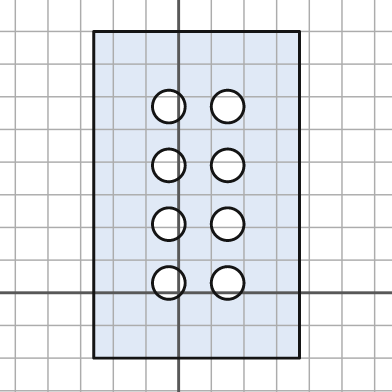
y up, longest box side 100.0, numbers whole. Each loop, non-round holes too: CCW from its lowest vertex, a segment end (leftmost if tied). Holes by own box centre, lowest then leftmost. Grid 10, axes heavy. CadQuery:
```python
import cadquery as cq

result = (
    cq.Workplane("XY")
    .moveTo(-26.0, -20.0)
    .lineTo(37.0, -20.0)
    .lineTo(37.0, 80.0)
    .lineTo(-26.0, 80.0)
    .close()
    .moveTo(-3.0, 3.0)
    .circle(5.0)
    .moveTo(15.0, 3.0)
    .circle(5.0)
    .moveTo(-3.0, 21.0)
    .circle(5.0)
    .moveTo(15.0, 21.0)
    .circle(5.0)
    .moveTo(-3.0, 39.0)
    .circle(5.0)
    .moveTo(15.0, 39.0)
    .circle(5.0)
    .moveTo(-3.0, 57.0)
    .circle(5.0)
    .moveTo(15.0, 57.0)
    .circle(5.0)
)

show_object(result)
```